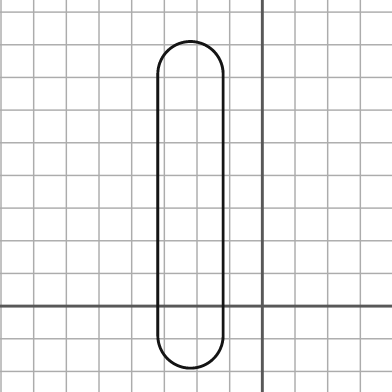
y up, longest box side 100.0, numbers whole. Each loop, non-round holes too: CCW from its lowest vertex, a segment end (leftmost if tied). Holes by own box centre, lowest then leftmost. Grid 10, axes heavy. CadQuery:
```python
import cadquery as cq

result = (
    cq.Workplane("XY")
    .moveTo(-32.0, -9.0)
    .threePointArc((-22.0, -19.0), (-12.0, -9.0))
    .lineTo(-12.0, 71.0)
    .threePointArc((-22.0, 81.0), (-32.0, 71.0))
    .close()
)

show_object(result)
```